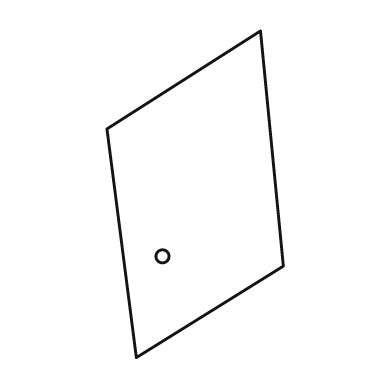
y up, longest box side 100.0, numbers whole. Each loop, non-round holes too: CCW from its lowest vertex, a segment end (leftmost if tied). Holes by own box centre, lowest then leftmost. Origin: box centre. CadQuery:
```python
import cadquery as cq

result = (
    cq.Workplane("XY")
    .moveTo(-18.0, -50.0)
    .lineTo(27.0, -22.0)
    .lineTo(20.0, 50.0)
    .lineTo(-27.0, 20.0)
    .close()
    .moveTo(-10.0, -19.0)
    .circle(2.0)
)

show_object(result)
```